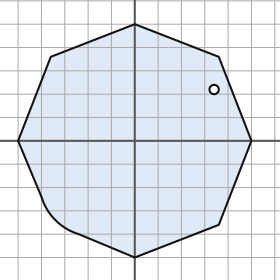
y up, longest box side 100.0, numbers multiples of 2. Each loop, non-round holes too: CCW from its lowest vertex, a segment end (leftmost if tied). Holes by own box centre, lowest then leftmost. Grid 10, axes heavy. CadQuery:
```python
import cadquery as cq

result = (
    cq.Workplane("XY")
    .moveTo(0.0, -50.0)
    .lineTo(36.0, -36.0)
    .lineTo(50.0, 0.0)
    .lineTo(36.0, 36.0)
    .lineTo(0.0, 50.0)
    .lineTo(-36.0, 36.0)
    .lineTo(-50.0, 0.0)
    .lineTo(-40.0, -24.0)
    .threePointArc((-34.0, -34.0), (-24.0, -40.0))
    .close()
    .moveTo(34.0, 22.0)
    .circle(2.0)
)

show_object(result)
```